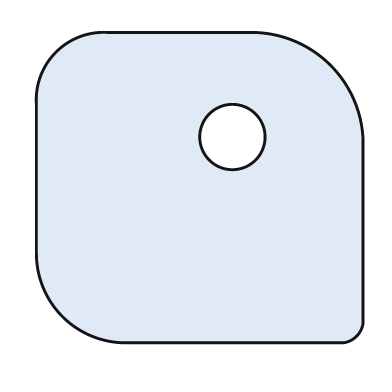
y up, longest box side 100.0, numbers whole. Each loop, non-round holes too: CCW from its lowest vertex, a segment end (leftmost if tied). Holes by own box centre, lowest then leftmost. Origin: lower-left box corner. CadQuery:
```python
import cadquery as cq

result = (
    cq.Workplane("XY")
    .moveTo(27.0, 0.0)
    .lineTo(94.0, 0.0)
    .threePointArc((98.0, 2.0), (100.0, 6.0))
    .lineTo(100.0, 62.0)
    .threePointArc((90.0, 85.0), (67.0, 95.0))
    .lineTo(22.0, 95.0)
    .threePointArc((6.0, 89.0), (0.0, 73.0))
    .lineTo(0.0, 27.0)
    .threePointArc((8.0, 8.0), (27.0, 0.0))
    .close()
    .moveTo(60.0, 63.0)
    .circle(10.0)
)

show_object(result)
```